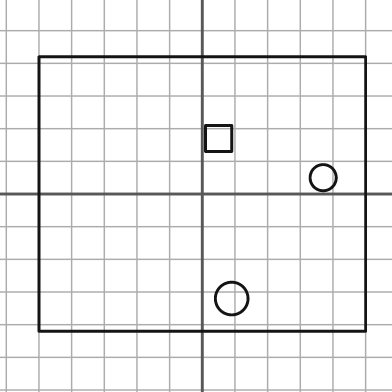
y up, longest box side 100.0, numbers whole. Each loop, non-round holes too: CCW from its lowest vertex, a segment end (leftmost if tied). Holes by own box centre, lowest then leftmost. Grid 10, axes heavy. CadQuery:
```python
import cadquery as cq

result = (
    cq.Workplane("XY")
    .moveTo(-50.0, -42.0)
    .lineTo(50.0, -42.0)
    .lineTo(50.0, 42.0)
    .lineTo(-50.0, 42.0)
    .close()
    .moveTo(9.0, -32.0)
    .circle(5.0)
    .moveTo(37.0, 5.0)
    .circle(4.0)
    .moveTo(1.0, 13.0)
    .lineTo(9.0, 13.0)
    .lineTo(9.0, 21.0)
    .lineTo(1.0, 21.0)
    .close()
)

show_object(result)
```